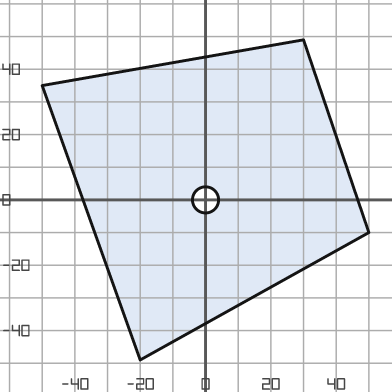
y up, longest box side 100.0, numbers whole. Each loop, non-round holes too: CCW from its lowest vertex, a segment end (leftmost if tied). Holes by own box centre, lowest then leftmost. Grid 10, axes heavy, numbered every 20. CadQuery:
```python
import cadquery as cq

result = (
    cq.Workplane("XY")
    .moveTo(-20.0, -49.0)
    .lineTo(50.0, -10.0)
    .lineTo(30.0, 49.0)
    .lineTo(-50.0, 35.0)
    .close()
    .moveTo(0.0, 0.0)
    .circle(4.0)
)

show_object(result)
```